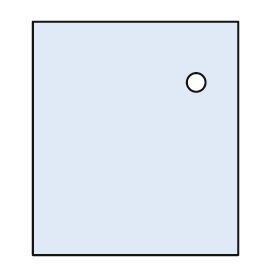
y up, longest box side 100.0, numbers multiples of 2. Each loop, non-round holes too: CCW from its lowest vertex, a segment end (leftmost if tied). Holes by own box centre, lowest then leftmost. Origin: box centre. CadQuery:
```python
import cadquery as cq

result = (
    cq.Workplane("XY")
    .moveTo(-44.0, -50.0)
    .lineTo(44.0, -50.0)
    .lineTo(44.0, 50.0)
    .lineTo(-44.0, 50.0)
    .close()
    .moveTo(26.0, 24.0)
    .circle(4.0)
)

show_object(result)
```